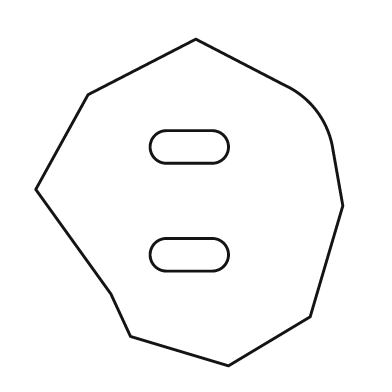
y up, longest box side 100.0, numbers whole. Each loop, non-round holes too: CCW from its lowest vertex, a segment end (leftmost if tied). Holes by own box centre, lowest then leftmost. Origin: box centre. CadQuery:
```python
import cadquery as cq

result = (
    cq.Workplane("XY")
    .moveTo(12.0, -50.0)
    .lineTo(37.0, -35.0)
    .lineTo(47.0, -1.0)
    .lineTo(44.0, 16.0)
    .threePointArc((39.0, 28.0), (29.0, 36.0))
    .lineTo(2.0, 50.0)
    .lineTo(-31.0, 33.0)
    .lineTo(-47.0, 4.0)
    .lineTo(-24.0, -28.0)
    .lineTo(-18.0, -41.0)
    .close()
    .moveTo(-7.0, -21.0)
    .lineTo(7.0, -21.0)
    .threePointArc((12.0, -16.0), (7.0, -11.0))
    .lineTo(-7.0, -11.0)
    .threePointArc((-12.0, -16.0), (-7.0, -21.0))
    .close()
    .moveTo(-7.0, 12.0)
    .lineTo(7.0, 12.0)
    .threePointArc((12.0, 17.0), (7.0, 22.0))
    .lineTo(-7.0, 22.0)
    .threePointArc((-12.0, 17.0), (-7.0, 12.0))
    .close()
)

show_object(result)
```